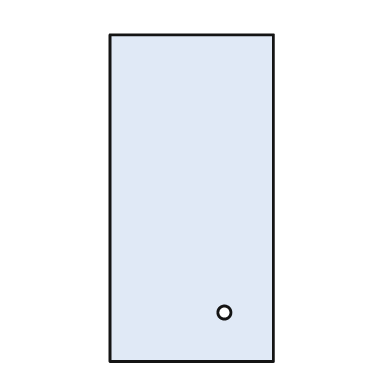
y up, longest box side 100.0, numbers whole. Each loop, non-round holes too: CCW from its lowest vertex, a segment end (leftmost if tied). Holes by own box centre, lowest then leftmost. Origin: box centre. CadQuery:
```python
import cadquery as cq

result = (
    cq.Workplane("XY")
    .moveTo(-25.0, -50.0)
    .lineTo(25.0, -50.0)
    .lineTo(25.0, 50.0)
    .lineTo(-25.0, 50.0)
    .close()
    .moveTo(10.0, -35.0)
    .circle(2.0)
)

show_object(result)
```